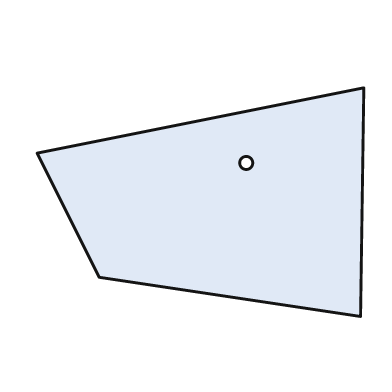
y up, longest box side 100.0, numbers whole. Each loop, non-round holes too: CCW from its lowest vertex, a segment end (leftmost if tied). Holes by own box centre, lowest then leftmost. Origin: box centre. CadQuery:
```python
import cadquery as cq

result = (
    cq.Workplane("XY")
    .moveTo(49.0, -35.0)
    .lineTo(50.0, 35.0)
    .lineTo(-50.0, 15.0)
    .lineTo(-31.0, -23.0)
    .close()
    .moveTo(14.0, 12.0)
    .circle(2.0)
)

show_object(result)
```